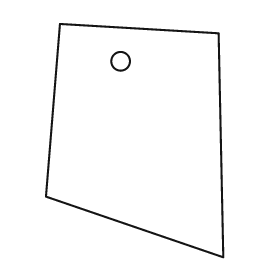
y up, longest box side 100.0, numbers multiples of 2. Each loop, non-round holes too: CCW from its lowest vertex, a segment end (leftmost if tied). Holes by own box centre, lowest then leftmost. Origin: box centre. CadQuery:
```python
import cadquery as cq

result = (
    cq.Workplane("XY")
    .moveTo(38.0, -50.0)
    .lineTo(36.0, 46.0)
    .lineTo(-32.0, 50.0)
    .lineTo(-38.0, -24.0)
    .close()
    .moveTo(-6.0, 34.0)
    .circle(4.0)
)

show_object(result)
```